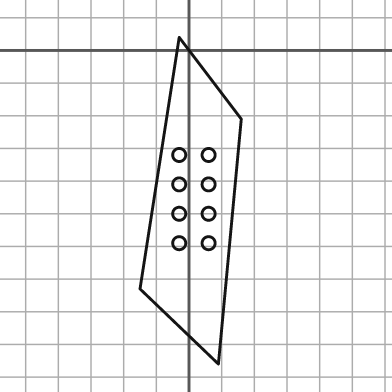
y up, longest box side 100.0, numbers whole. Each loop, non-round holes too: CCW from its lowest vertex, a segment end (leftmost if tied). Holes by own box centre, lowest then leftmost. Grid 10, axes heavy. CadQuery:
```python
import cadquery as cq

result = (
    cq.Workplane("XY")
    .moveTo(9.0, -96.0)
    .lineTo(16.0, -21.0)
    .lineTo(-3.0, 4.0)
    .lineTo(-15.0, -73.0)
    .close()
    .moveTo(-3.0, -59.0)
    .circle(2.0)
    .moveTo(6.0, -59.0)
    .circle(2.0)
    .moveTo(-3.0, -50.0)
    .circle(2.0)
    .moveTo(6.0, -50.0)
    .circle(2.0)
    .moveTo(-3.0, -41.0)
    .circle(2.0)
    .moveTo(6.0, -41.0)
    .circle(2.0)
    .moveTo(-3.0, -32.0)
    .circle(2.0)
    .moveTo(6.0, -32.0)
    .circle(2.0)
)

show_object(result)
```